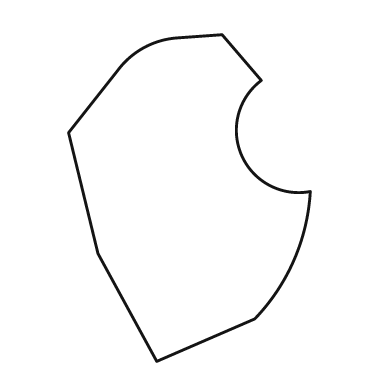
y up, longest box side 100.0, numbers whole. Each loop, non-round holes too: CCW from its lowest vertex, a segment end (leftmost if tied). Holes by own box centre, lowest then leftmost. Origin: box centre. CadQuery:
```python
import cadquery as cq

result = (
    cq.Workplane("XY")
    .moveTo(-10.0, -50.0)
    .lineTo(20.0, -37.0)
    .threePointArc((32.0, -19.0), (37.0, 2.0))
    .threePointArc((16.0, 13.0), (22.0, 36.0))
    .lineTo(10.0, 50.0)
    .lineTo(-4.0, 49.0)
    .threePointArc((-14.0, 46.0), (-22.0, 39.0))
    .lineTo(-37.0, 20.0)
    .lineTo(-28.0, -17.0)
    .close()
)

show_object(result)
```